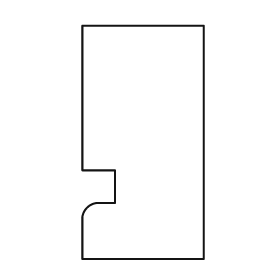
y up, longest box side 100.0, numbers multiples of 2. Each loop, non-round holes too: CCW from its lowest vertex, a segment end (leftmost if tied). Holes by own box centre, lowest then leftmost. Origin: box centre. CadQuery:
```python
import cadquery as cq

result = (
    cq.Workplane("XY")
    .moveTo(-26.0, -50.0)
    .lineTo(26.0, -50.0)
    .lineTo(26.0, 50.0)
    .lineTo(-26.0, 50.0)
    .lineTo(-26.0, -12.0)
    .lineTo(-12.0, -12.0)
    .lineTo(-12.0, -26.0)
    .lineTo(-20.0, -26.0)
    .threePointArc((-24.0, -28.0), (-26.0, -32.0))
    .close()
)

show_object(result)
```